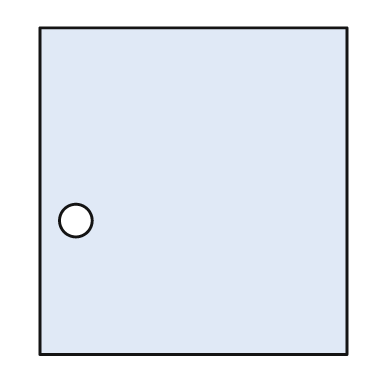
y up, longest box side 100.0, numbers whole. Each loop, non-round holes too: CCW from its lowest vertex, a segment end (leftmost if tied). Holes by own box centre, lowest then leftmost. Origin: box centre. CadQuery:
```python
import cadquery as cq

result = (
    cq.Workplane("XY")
    .moveTo(-47.0, -50.0)
    .lineTo(47.0, -50.0)
    .lineTo(47.0, 50.0)
    .lineTo(-47.0, 50.0)
    .close()
    .moveTo(-36.0, -9.0)
    .circle(5.0)
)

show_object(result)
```